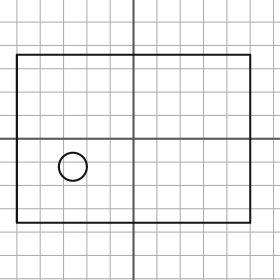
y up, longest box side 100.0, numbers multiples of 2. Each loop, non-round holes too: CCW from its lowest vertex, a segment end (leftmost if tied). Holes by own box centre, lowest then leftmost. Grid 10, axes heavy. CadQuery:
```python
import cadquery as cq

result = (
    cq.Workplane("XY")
    .moveTo(-50.0, -36.0)
    .lineTo(50.0, -36.0)
    .lineTo(50.0, 36.0)
    .lineTo(-50.0, 36.0)
    .close()
    .moveTo(-26.0, -12.0)
    .circle(6.0)
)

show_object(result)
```